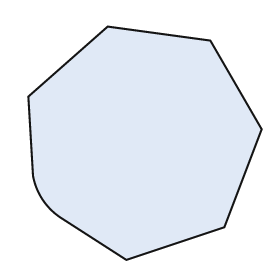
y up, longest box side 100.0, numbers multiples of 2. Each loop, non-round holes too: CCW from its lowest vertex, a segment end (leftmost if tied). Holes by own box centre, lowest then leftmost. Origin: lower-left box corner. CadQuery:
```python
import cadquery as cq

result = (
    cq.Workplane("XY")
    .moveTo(42.0, 0.0)
    .lineTo(84.0, 14.0)
    .lineTo(100.0, 56.0)
    .lineTo(78.0, 94.0)
    .lineTo(34.0, 100.0)
    .lineTo(0.0, 70.0)
    .lineTo(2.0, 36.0)
    .threePointArc((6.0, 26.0), (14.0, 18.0))
    .close()
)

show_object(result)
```